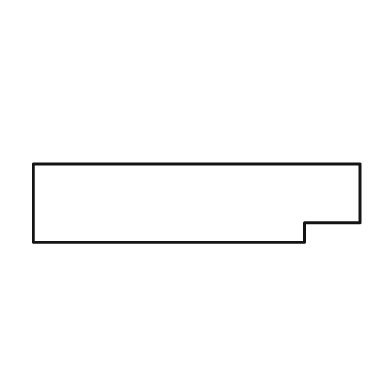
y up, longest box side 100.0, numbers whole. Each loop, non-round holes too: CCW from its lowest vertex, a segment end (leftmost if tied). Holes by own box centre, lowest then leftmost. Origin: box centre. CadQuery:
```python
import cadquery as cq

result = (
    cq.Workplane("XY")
    .moveTo(-50.0, -12.0)
    .lineTo(33.0, -12.0)
    .lineTo(33.0, -6.0)
    .lineTo(50.0, -6.0)
    .lineTo(50.0, 12.0)
    .lineTo(-50.0, 12.0)
    .close()
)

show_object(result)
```